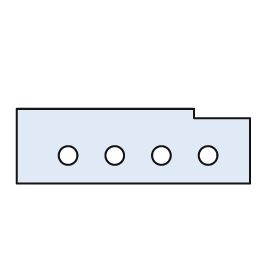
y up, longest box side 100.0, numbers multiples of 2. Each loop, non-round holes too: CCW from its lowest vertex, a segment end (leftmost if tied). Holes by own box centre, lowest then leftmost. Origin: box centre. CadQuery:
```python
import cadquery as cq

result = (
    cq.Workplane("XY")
    .moveTo(-50.0, -16.0)
    .lineTo(50.0, -16.0)
    .lineTo(50.0, 12.0)
    .lineTo(26.0, 12.0)
    .lineTo(26.0, 16.0)
    .lineTo(-50.0, 16.0)
    .close()
    .moveTo(-28.0, -4.0)
    .circle(4.0)
    .moveTo(-8.0, -4.0)
    .circle(4.0)
    .moveTo(12.0, -4.0)
    .circle(4.0)
    .moveTo(32.0, -4.0)
    .circle(4.0)
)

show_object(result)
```